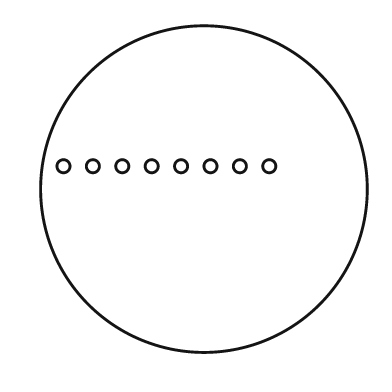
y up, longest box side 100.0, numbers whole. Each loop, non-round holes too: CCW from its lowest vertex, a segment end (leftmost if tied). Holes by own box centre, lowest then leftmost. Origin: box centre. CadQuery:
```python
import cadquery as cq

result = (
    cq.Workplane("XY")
    .moveTo(0.0, 0.0)
    .circle(50.0)
    .moveTo(-43.0, 7.0)
    .circle(2.0)
    .moveTo(-34.0, 7.0)
    .circle(2.0)
    .moveTo(-25.0, 7.0)
    .circle(2.0)
    .moveTo(-16.0, 7.0)
    .circle(2.0)
    .moveTo(-7.0, 7.0)
    .circle(2.0)
    .moveTo(2.0, 7.0)
    .circle(2.0)
    .moveTo(11.0, 7.0)
    .circle(2.0)
    .moveTo(20.0, 7.0)
    .circle(2.0)
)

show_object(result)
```